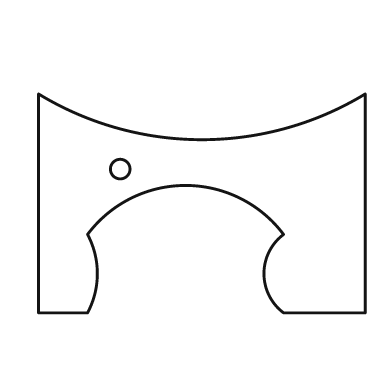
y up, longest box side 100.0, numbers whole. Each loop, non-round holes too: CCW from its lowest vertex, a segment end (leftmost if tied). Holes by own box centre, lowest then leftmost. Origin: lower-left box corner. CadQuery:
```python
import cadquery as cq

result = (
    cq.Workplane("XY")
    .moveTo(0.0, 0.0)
    .lineTo(15.0, 0.0)
    .threePointArc((18.0, 12.0), (15.0, 24.0))
    .threePointArc((45.0, 39.0), (75.0, 24.0))
    .threePointArc((69.0, 12.0), (75.0, 0.0))
    .lineTo(100.0, 0.0)
    .lineTo(100.0, 67.0)
    .threePointArc((50.0, 53.0), (0.0, 67.0))
    .close()
    .moveTo(25.0, 44.0)
    .circle(3.0)
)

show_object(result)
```